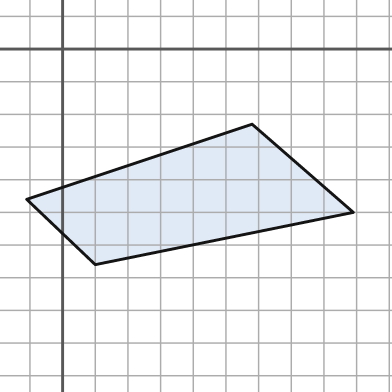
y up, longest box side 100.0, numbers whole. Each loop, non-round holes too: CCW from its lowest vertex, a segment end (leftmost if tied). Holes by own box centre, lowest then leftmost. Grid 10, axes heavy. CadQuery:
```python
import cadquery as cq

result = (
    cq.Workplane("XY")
    .moveTo(10.0, -66.0)
    .lineTo(89.0, -50.0)
    .lineTo(58.0, -23.0)
    .lineTo(-11.0, -46.0)
    .close()
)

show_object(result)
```